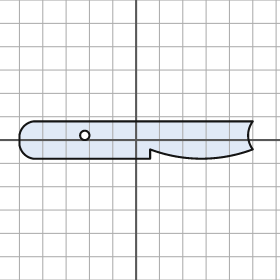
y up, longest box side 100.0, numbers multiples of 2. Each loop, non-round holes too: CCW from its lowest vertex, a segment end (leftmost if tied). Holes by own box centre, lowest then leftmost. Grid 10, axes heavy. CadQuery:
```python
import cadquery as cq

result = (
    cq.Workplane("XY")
    .moveTo(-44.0, -8.0)
    .lineTo(6.0, -8.0)
    .lineTo(6.0, -4.0)
    .threePointArc((28.0, -8.0), (50.0, -4.0))
    .threePointArc((48.0, 2.0), (50.0, 8.0))
    .lineTo(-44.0, 8.0)
    .threePointArc((-48.0, 6.0), (-50.0, 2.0))
    .lineTo(-50.0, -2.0)
    .threePointArc((-48.0, -6.0), (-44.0, -8.0))
    .close()
    .moveTo(-22.0, 2.0)
    .circle(2.0)
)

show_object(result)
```